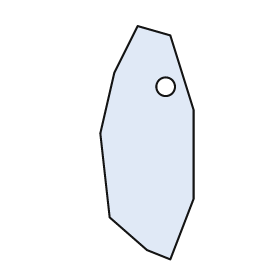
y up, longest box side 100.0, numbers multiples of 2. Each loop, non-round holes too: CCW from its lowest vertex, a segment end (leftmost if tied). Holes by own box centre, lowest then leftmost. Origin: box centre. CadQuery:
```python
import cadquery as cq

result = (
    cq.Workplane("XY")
    .moveTo(10.0, -50.0)
    .lineTo(20.0, -24.0)
    .lineTo(20.0, 14.0)
    .lineTo(10.0, 46.0)
    .lineTo(-4.0, 50.0)
    .lineTo(-14.0, 30.0)
    .lineTo(-20.0, 4.0)
    .lineTo(-16.0, -32.0)
    .lineTo(0.0, -46.0)
    .close()
    .moveTo(8.0, 24.0)
    .circle(4.0)
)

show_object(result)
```